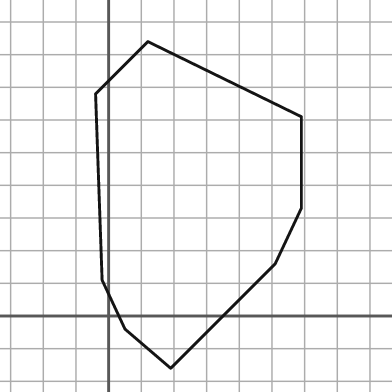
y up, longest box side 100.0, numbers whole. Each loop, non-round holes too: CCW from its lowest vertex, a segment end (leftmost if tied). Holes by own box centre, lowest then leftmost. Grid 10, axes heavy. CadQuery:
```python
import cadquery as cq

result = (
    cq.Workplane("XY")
    .moveTo(19.0, -16.0)
    .lineTo(51.0, 16.0)
    .lineTo(59.0, 33.0)
    .lineTo(59.0, 61.0)
    .lineTo(12.0, 84.0)
    .lineTo(-4.0, 68.0)
    .lineTo(-2.0, 11.0)
    .lineTo(5.0, -4.0)
    .close()
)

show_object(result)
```